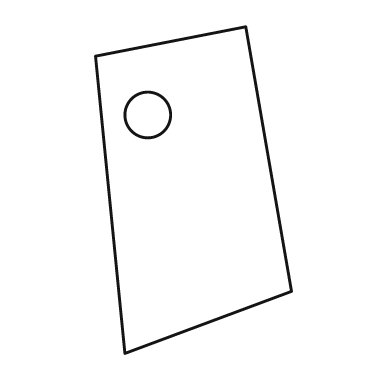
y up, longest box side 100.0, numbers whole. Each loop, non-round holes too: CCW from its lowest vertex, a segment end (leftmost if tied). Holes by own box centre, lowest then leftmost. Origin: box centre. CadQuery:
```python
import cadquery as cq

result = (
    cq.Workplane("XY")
    .moveTo(-21.0, -50.0)
    .lineTo(30.0, -31.0)
    .lineTo(16.0, 50.0)
    .lineTo(-30.0, 41.0)
    .close()
    .moveTo(-14.0, 23.0)
    .circle(7.0)
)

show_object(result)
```